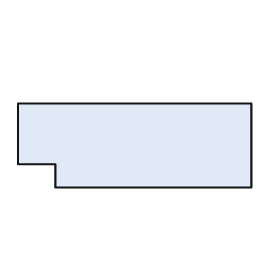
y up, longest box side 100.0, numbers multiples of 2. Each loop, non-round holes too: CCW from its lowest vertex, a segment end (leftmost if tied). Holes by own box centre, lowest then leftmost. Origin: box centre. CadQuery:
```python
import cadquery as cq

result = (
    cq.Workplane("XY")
    .moveTo(-34.0, -18.0)
    .lineTo(50.0, -18.0)
    .lineTo(50.0, 18.0)
    .lineTo(-50.0, 18.0)
    .lineTo(-50.0, -8.0)
    .lineTo(-34.0, -8.0)
    .close()
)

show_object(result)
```